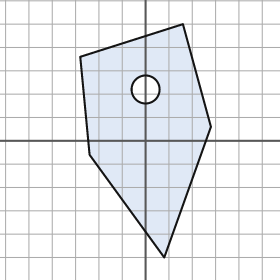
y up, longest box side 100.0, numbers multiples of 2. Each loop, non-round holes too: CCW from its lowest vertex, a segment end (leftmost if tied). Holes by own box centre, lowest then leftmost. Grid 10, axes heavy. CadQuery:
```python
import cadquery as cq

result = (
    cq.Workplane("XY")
    .moveTo(8.0, -50.0)
    .lineTo(28.0, 6.0)
    .lineTo(16.0, 50.0)
    .lineTo(-28.0, 36.0)
    .lineTo(-24.0, -6.0)
    .close()
    .moveTo(0.0, 22.0)
    .circle(6.0)
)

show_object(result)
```